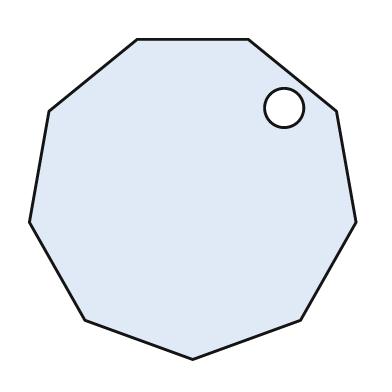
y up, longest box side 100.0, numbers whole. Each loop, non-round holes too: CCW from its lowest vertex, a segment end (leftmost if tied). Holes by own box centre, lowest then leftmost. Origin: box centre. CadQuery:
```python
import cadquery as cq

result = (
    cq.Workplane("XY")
    .moveTo(0.0, -49.0)
    .lineTo(33.0, -37.0)
    .lineTo(50.0, -7.0)
    .lineTo(44.0, 27.0)
    .lineTo(17.0, 49.0)
    .lineTo(-17.0, 49.0)
    .lineTo(-44.0, 27.0)
    .lineTo(-50.0, -7.0)
    .lineTo(-33.0, -37.0)
    .close()
    .moveTo(28.0, 28.0)
    .circle(6.0)
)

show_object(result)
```